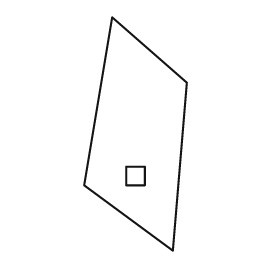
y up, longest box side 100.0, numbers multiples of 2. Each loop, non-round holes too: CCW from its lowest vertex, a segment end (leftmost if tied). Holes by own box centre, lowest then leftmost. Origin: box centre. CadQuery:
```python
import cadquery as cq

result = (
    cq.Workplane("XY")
    .moveTo(16.0, -50.0)
    .lineTo(22.0, 22.0)
    .lineTo(-10.0, 50.0)
    .lineTo(-22.0, -22.0)
    .close()
    .moveTo(-4.0, -22.0)
    .lineTo(4.0, -22.0)
    .lineTo(4.0, -14.0)
    .lineTo(-4.0, -14.0)
    .close()
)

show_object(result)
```